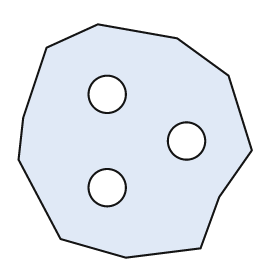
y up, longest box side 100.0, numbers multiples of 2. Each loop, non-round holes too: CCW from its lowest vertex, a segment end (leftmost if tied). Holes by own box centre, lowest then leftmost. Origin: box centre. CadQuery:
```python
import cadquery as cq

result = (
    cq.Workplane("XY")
    .moveTo(-4.0, -50.0)
    .lineTo(28.0, -46.0)
    .lineTo(36.0, -24.0)
    .lineTo(50.0, -4.0)
    .lineTo(40.0, 28.0)
    .lineTo(18.0, 44.0)
    .lineTo(-16.0, 50.0)
    .lineTo(-38.0, 40.0)
    .lineTo(-48.0, 10.0)
    .lineTo(-50.0, -8.0)
    .lineTo(-32.0, -42.0)
    .close()
    .moveTo(-12.0, -20.0)
    .circle(8.0)
    .moveTo(22.0, 0.0)
    .circle(8.0)
    .moveTo(-12.0, 20.0)
    .circle(8.0)
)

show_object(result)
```